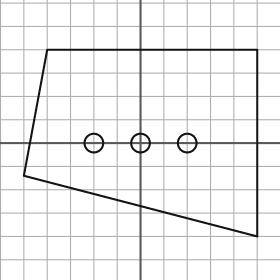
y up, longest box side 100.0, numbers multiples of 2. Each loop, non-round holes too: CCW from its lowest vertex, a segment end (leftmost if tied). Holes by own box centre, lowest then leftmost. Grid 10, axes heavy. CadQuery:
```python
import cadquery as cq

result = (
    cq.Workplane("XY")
    .moveTo(50.0, -40.0)
    .lineTo(50.0, 40.0)
    .lineTo(-40.0, 40.0)
    .lineTo(-50.0, -14.0)
    .close()
    .moveTo(-20.0, 0.0)
    .circle(4.0)
    .moveTo(0.0, 0.0)
    .circle(4.0)
    .moveTo(20.0, 0.0)
    .circle(4.0)
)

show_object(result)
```